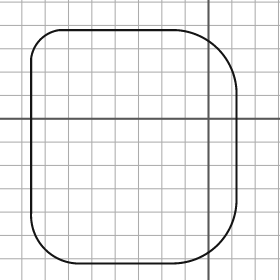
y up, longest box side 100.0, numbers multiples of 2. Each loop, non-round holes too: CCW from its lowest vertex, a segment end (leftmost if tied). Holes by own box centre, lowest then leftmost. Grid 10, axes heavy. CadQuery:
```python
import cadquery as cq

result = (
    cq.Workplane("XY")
    .moveTo(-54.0, -62.0)
    .lineTo(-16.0, -62.0)
    .threePointArc((4.0, -54.0), (12.0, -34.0))
    .lineTo(12.0, 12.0)
    .threePointArc((4.0, 30.0), (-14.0, 38.0))
    .lineTo(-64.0, 38.0)
    .threePointArc((-72.0, 34.0), (-76.0, 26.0))
    .lineTo(-76.0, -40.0)
    .threePointArc((-70.0, -56.0), (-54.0, -62.0))
    .close()
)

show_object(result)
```